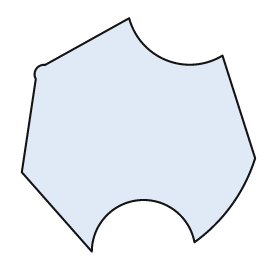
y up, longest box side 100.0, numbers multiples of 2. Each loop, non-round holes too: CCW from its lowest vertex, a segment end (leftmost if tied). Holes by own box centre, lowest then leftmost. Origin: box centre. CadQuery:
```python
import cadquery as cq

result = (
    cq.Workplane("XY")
    .moveTo(-20.0, -50.0)
    .threePointArc((0.0, -28.0), (24.0, -46.0))
    .threePointArc((40.0, -30.0), (50.0, -10.0))
    .lineTo(36.0, 34.0)
    .threePointArc((12.0, 32.0), (-4.0, 50.0))
    .lineTo(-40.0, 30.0)
    .threePointArc((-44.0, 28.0), (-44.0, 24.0))
    .lineTo(-50.0, -16.0)
    .close()
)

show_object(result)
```